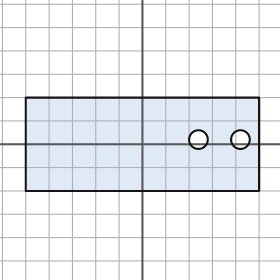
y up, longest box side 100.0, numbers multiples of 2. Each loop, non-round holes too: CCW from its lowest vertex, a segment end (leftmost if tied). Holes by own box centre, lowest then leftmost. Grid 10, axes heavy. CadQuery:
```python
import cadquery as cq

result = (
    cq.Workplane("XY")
    .moveTo(-50.0, -20.0)
    .lineTo(50.0, -20.0)
    .lineTo(50.0, 20.0)
    .lineTo(-50.0, 20.0)
    .close()
    .moveTo(24.0, 2.0)
    .circle(4.0)
    .moveTo(42.0, 2.0)
    .circle(4.0)
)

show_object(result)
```